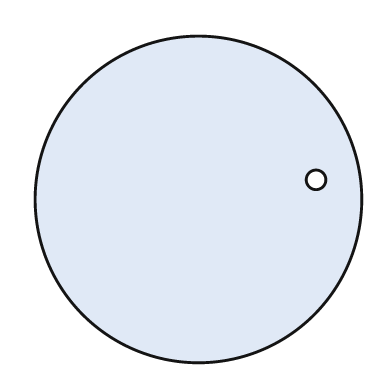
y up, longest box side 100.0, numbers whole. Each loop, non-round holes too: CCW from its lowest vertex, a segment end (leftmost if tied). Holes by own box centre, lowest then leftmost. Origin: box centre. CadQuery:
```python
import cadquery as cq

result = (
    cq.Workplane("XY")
    .moveTo(0.0, 0.0)
    .circle(50.0)
    .moveTo(36.0, 6.0)
    .circle(3.0)
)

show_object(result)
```